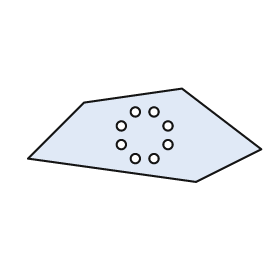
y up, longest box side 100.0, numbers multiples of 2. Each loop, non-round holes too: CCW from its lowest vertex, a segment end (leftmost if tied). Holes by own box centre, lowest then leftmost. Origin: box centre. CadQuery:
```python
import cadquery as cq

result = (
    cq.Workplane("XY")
    .moveTo(22.0, -20.0)
    .lineTo(50.0, -6.0)
    .lineTo(16.0, 20.0)
    .lineTo(-26.0, 14.0)
    .lineTo(-50.0, -10.0)
    .close()
    .moveTo(-4.0, -10.0)
    .circle(2.0)
    .moveTo(4.0, -10.0)
    .circle(2.0)
    .moveTo(-10.0, -4.0)
    .circle(2.0)
    .moveTo(10.0, -4.0)
    .circle(2.0)
    .moveTo(-10.0, 4.0)
    .circle(2.0)
    .moveTo(10.0, 4.0)
    .circle(2.0)
    .moveTo(-4.0, 10.0)
    .circle(2.0)
    .moveTo(4.0, 10.0)
    .circle(2.0)
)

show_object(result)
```